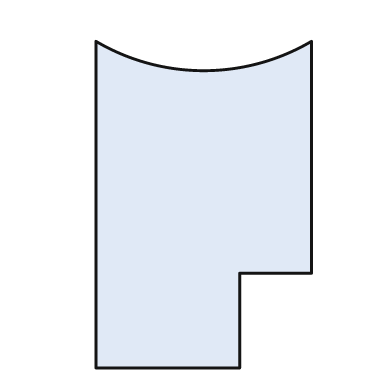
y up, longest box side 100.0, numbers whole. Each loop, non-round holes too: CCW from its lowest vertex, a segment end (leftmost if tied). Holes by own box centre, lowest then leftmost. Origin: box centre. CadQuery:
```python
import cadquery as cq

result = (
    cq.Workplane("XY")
    .moveTo(-33.0, -50.0)
    .lineTo(11.0, -50.0)
    .lineTo(11.0, -21.0)
    .lineTo(33.0, -21.0)
    .lineTo(33.0, 50.0)
    .threePointArc((0.0, 41.0), (-33.0, 50.0))
    .close()
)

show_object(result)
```